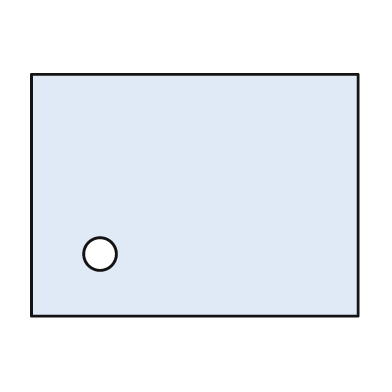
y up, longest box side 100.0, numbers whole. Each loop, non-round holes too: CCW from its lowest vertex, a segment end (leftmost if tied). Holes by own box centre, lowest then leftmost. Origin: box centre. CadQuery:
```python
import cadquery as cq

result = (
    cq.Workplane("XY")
    .moveTo(-50.0, -37.0)
    .lineTo(50.0, -37.0)
    .lineTo(50.0, 37.0)
    .lineTo(-50.0, 37.0)
    .close()
    .moveTo(-29.0, -18.0)
    .circle(5.0)
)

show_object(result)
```